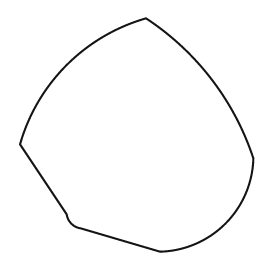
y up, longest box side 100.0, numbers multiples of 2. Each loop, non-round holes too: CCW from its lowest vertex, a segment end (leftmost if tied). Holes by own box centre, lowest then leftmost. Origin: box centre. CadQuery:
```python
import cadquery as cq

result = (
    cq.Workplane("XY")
    .moveTo(10.0, -50.0)
    .threePointArc((38.0, -38.0), (50.0, -10.0))
    .threePointArc((32.0, 24.0), (4.0, 50.0))
    .threePointArc((-30.0, 30.0), (-50.0, -4.0))
    .lineTo(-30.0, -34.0)
    .threePointArc((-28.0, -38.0), (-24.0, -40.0))
    .close()
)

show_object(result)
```